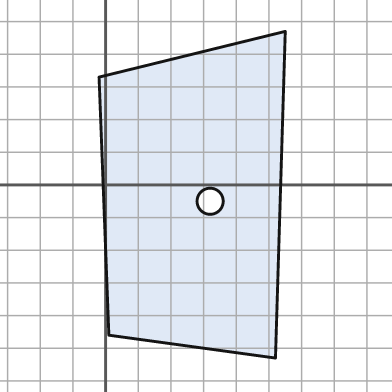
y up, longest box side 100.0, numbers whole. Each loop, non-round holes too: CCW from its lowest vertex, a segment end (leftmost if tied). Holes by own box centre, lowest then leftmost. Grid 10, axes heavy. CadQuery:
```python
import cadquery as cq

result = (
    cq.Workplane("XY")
    .moveTo(52.0, -53.0)
    .lineTo(55.0, 47.0)
    .lineTo(-2.0, 33.0)
    .lineTo(1.0, -46.0)
    .close()
    .moveTo(32.0, -5.0)
    .circle(4.0)
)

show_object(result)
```